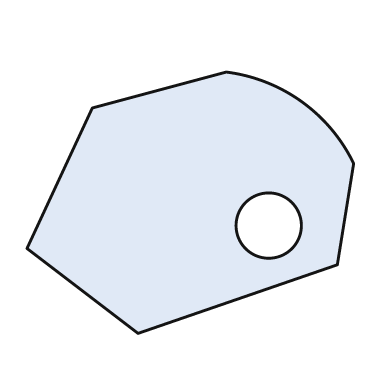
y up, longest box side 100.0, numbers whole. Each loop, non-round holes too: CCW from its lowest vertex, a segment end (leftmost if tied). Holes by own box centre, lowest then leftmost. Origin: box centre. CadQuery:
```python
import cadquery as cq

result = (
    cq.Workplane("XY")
    .moveTo(-16.0, -40.0)
    .lineTo(45.0, -19.0)
    .lineTo(50.0, 12.0)
    .threePointArc((34.0, 31.0), (11.0, 40.0))
    .lineTo(-30.0, 29.0)
    .lineTo(-50.0, -14.0)
    .close()
    .moveTo(24.0, -7.0)
    .circle(10.0)
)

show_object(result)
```